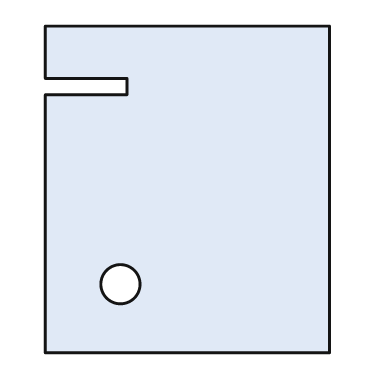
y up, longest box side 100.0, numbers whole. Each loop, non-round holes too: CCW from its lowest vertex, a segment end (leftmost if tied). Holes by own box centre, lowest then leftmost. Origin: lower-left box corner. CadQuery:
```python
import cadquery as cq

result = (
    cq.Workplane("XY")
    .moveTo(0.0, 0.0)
    .lineTo(87.0, 0.0)
    .lineTo(87.0, 100.0)
    .lineTo(0.0, 100.0)
    .lineTo(0.0, 84.0)
    .lineTo(25.0, 84.0)
    .lineTo(25.0, 79.0)
    .lineTo(0.0, 79.0)
    .close()
    .moveTo(23.0, 21.0)
    .circle(6.0)
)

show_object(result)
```